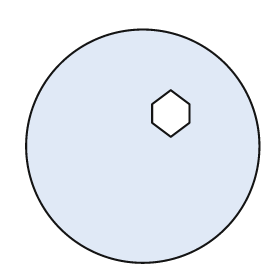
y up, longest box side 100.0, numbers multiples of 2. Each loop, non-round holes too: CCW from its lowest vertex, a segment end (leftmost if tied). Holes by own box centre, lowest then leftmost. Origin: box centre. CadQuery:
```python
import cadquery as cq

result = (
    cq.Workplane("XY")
    .moveTo(0.0, 0.0)
    .circle(50.0)
    .moveTo(12.0, 4.0)
    .lineTo(20.0, 10.0)
    .lineTo(20.0, 18.0)
    .lineTo(12.0, 24.0)
    .lineTo(4.0, 18.0)
    .lineTo(4.0, 10.0)
    .close()
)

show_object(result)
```